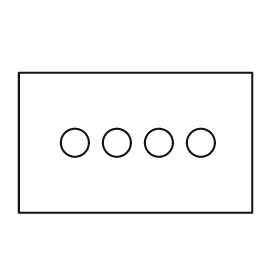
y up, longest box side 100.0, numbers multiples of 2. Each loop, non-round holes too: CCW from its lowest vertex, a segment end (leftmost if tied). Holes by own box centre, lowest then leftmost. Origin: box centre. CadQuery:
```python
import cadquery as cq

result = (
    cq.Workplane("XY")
    .moveTo(-50.0, -30.0)
    .lineTo(50.0, -30.0)
    .lineTo(50.0, 30.0)
    .lineTo(-50.0, 30.0)
    .close()
    .moveTo(-26.0, 0.0)
    .circle(6.0)
    .moveTo(-8.0, 0.0)
    .circle(6.0)
    .moveTo(10.0, 0.0)
    .circle(6.0)
    .moveTo(28.0, 0.0)
    .circle(6.0)
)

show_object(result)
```